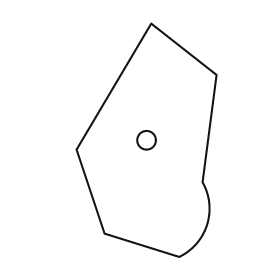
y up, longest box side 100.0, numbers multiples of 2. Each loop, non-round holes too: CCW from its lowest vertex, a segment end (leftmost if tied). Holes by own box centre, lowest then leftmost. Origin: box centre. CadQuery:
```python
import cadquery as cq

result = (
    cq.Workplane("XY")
    .moveTo(14.0, -50.0)
    .threePointArc((26.0, -36.0), (24.0, -18.0))
    .lineTo(30.0, 28.0)
    .lineTo(2.0, 50.0)
    .lineTo(-30.0, -4.0)
    .lineTo(-18.0, -40.0)
    .close()
    .moveTo(0.0, 0.0)
    .circle(4.0)
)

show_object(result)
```